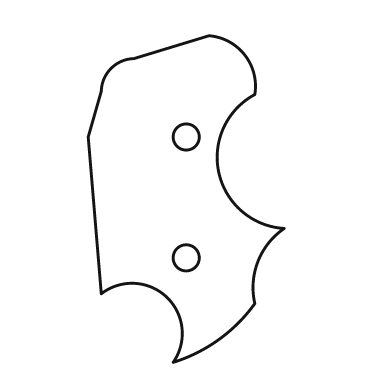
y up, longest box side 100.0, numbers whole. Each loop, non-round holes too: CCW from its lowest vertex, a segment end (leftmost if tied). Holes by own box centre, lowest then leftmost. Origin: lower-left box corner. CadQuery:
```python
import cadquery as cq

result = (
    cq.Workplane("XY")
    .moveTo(26.0, 0.0)
    .threePointArc((40.0, 7.0), (51.0, 18.0))
    .threePointArc((52.0, 31.0), (60.0, 41.0))
    .threePointArc((40.0, 58.0), (51.0, 82.0))
    .threePointArc((48.0, 94.0), (37.0, 100.0))
    .lineTo(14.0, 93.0)
    .threePointArc((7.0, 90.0), (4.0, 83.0))
    .lineTo(0.0, 69.0)
    .lineTo(4.0, 21.0)
    .threePointArc((24.0, 20.0), (26.0, 0.0))
    .close()
    .moveTo(30.0, 32.0)
    .circle(4.0)
    .moveTo(30.0, 69.0)
    .circle(4.0)
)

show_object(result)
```